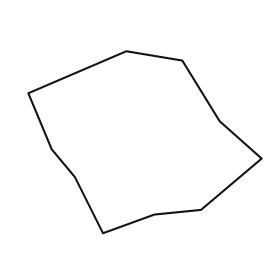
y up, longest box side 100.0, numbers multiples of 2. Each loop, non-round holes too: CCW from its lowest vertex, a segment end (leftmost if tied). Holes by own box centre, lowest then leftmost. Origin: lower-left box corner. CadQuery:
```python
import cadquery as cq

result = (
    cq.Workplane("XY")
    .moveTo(32.0, 0.0)
    .lineTo(54.0, 8.0)
    .lineTo(74.0, 10.0)
    .lineTo(100.0, 32.0)
    .lineTo(82.0, 48.0)
    .lineTo(66.0, 74.0)
    .lineTo(42.0, 78.0)
    .lineTo(0.0, 60.0)
    .lineTo(10.0, 36.0)
    .lineTo(20.0, 24.0)
    .close()
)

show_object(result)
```